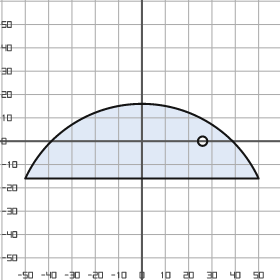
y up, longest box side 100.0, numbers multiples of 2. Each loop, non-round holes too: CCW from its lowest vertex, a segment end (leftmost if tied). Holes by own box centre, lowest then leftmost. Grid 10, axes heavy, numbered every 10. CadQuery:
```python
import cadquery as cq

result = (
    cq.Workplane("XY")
    .moveTo(-50.0, -16.0)
    .lineTo(50.0, -16.0)
    .threePointArc((0.0, 16.0), (-50.0, -16.0))
    .close()
    .moveTo(26.0, 0.0)
    .circle(2.0)
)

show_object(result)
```